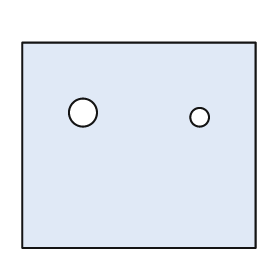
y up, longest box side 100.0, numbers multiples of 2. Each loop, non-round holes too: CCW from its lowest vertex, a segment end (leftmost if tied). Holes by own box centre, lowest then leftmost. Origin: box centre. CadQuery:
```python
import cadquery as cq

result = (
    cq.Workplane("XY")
    .moveTo(-50.0, -44.0)
    .lineTo(50.0, -44.0)
    .lineTo(50.0, 44.0)
    .lineTo(-50.0, 44.0)
    .close()
    .moveTo(26.0, 12.0)
    .circle(4.0)
    .moveTo(-24.0, 14.0)
    .circle(6.0)
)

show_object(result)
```